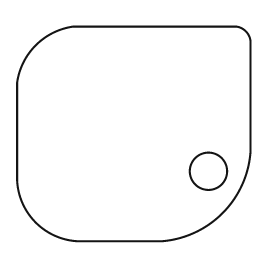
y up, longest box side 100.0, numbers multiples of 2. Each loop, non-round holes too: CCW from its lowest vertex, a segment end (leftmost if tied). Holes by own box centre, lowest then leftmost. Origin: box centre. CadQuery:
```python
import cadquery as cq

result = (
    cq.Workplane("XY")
    .moveTo(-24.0, -46.0)
    .lineTo(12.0, -46.0)
    .threePointArc((38.0, -34.0), (50.0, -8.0))
    .lineTo(50.0, 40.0)
    .threePointArc((48.0, 44.0), (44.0, 46.0))
    .lineTo(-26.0, 46.0)
    .threePointArc((-42.0, 38.0), (-50.0, 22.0))
    .lineTo(-50.0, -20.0)
    .threePointArc((-42.0, -38.0), (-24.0, -46.0))
    .close()
    .moveTo(32.0, -16.0)
    .circle(8.0)
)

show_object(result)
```